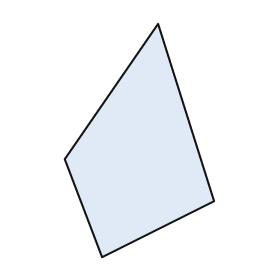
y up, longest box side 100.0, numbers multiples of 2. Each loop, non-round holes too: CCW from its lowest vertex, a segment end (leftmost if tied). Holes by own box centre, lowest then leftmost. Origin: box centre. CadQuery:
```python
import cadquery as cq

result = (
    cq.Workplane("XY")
    .moveTo(-16.0, -50.0)
    .lineTo(32.0, -26.0)
    .lineTo(8.0, 50.0)
    .lineTo(-32.0, -8.0)
    .close()
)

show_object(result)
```